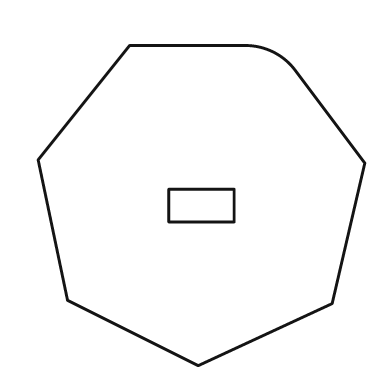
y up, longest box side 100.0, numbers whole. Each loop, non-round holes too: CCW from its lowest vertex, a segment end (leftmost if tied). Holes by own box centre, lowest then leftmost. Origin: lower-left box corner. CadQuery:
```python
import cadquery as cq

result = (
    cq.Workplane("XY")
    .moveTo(49.0, 0.0)
    .lineTo(90.0, 19.0)
    .lineTo(100.0, 62.0)
    .lineTo(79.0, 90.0)
    .threePointArc((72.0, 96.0), (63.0, 98.0))
    .lineTo(28.0, 98.0)
    .lineTo(0.0, 63.0)
    .lineTo(9.0, 20.0)
    .close()
    .moveTo(40.0, 44.0)
    .lineTo(60.0, 44.0)
    .lineTo(60.0, 54.0)
    .lineTo(40.0, 54.0)
    .close()
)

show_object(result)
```